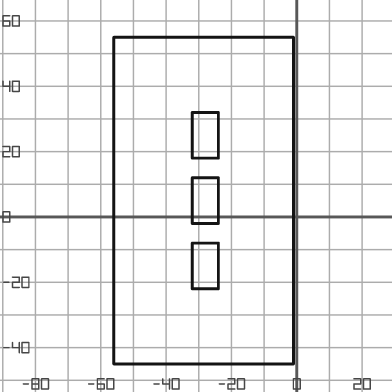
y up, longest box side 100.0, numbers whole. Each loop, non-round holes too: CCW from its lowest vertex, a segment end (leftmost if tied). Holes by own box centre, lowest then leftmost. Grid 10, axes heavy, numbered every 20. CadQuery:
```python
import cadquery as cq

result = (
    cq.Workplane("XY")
    .moveTo(-56.0, -45.0)
    .lineTo(-1.0, -45.0)
    .lineTo(-1.0, 55.0)
    .lineTo(-56.0, 55.0)
    .close()
    .moveTo(-32.0, -22.0)
    .lineTo(-24.0, -22.0)
    .lineTo(-24.0, -8.0)
    .lineTo(-32.0, -8.0)
    .close()
    .moveTo(-32.0, -2.0)
    .lineTo(-24.0, -2.0)
    .lineTo(-24.0, 12.0)
    .lineTo(-32.0, 12.0)
    .close()
    .moveTo(-32.0, 18.0)
    .lineTo(-24.0, 18.0)
    .lineTo(-24.0, 32.0)
    .lineTo(-32.0, 32.0)
    .close()
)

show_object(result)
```